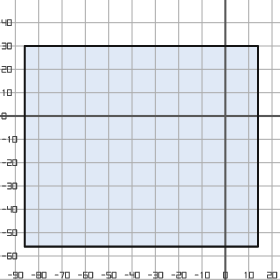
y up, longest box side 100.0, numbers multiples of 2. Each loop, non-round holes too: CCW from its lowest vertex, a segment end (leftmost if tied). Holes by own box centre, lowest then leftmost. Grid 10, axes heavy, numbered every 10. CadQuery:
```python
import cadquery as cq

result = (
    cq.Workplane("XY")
    .moveTo(-86.0, -56.0)
    .lineTo(14.0, -56.0)
    .lineTo(14.0, 30.0)
    .lineTo(-86.0, 30.0)
    .close()
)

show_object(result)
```